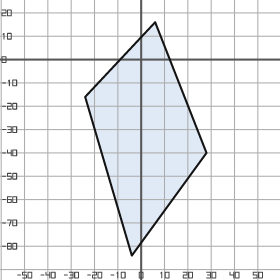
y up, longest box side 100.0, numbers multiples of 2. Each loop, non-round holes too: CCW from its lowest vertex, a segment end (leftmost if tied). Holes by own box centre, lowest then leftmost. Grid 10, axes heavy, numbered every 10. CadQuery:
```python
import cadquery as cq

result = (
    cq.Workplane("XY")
    .moveTo(-4.0, -84.0)
    .lineTo(28.0, -40.0)
    .lineTo(6.0, 16.0)
    .lineTo(-24.0, -16.0)
    .close()
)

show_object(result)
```